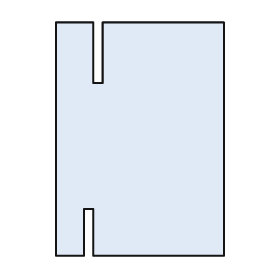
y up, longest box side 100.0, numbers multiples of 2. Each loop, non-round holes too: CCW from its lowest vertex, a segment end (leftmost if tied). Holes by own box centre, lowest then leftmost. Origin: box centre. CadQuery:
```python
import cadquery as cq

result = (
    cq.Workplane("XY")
    .moveTo(-36.0, -50.0)
    .lineTo(-24.0, -50.0)
    .lineTo(-24.0, -30.0)
    .lineTo(-20.0, -30.0)
    .lineTo(-20.0, -50.0)
    .lineTo(36.0, -50.0)
    .lineTo(36.0, 50.0)
    .lineTo(-16.0, 50.0)
    .lineTo(-16.0, 24.0)
    .lineTo(-20.0, 24.0)
    .lineTo(-20.0, 50.0)
    .lineTo(-36.0, 50.0)
    .close()
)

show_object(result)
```